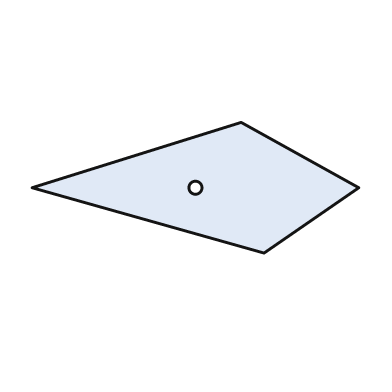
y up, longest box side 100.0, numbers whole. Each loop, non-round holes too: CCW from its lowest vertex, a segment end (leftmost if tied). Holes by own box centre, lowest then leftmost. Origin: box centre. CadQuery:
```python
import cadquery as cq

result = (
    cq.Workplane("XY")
    .moveTo(21.0, -20.0)
    .lineTo(50.0, 0.0)
    .lineTo(14.0, 20.0)
    .lineTo(-50.0, 0.0)
    .close()
    .moveTo(0.0, 0.0)
    .circle(2.0)
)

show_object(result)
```